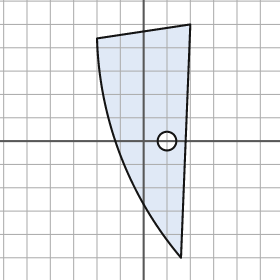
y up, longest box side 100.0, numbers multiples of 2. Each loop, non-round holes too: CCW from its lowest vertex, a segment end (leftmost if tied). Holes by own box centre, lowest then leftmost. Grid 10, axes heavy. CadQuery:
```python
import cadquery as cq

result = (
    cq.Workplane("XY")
    .moveTo(16.0, -50.0)
    .lineTo(20.0, 50.0)
    .lineTo(-20.0, 44.0)
    .threePointArc((-10.0, -6.0), (16.0, -50.0))
    .close()
    .moveTo(10.0, 0.0)
    .circle(4.0)
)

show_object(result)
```